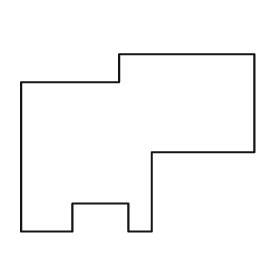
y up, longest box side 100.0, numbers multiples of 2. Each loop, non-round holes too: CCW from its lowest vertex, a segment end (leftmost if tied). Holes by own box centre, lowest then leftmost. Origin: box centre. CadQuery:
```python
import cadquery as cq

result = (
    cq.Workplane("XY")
    .moveTo(-50.0, -38.0)
    .lineTo(-28.0, -38.0)
    .lineTo(-28.0, -26.0)
    .lineTo(-4.0, -26.0)
    .lineTo(-4.0, -38.0)
    .lineTo(6.0, -38.0)
    .lineTo(6.0, -4.0)
    .lineTo(50.0, -4.0)
    .lineTo(50.0, 38.0)
    .lineTo(-8.0, 38.0)
    .lineTo(-8.0, 26.0)
    .lineTo(-50.0, 26.0)
    .close()
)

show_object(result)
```